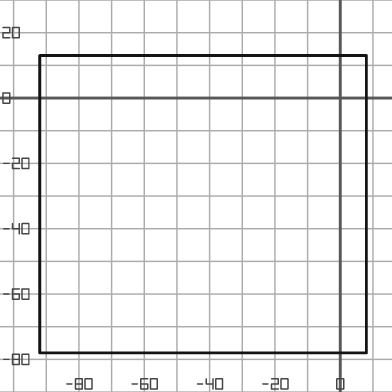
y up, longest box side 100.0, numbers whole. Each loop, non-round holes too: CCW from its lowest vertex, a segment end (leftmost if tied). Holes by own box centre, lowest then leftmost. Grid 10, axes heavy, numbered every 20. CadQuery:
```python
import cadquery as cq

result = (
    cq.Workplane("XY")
    .moveTo(-92.0, -78.0)
    .lineTo(8.0, -78.0)
    .lineTo(8.0, 13.0)
    .lineTo(-92.0, 13.0)
    .close()
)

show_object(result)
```